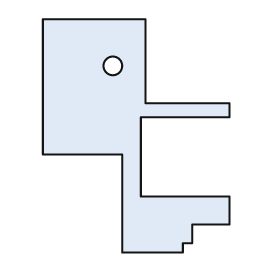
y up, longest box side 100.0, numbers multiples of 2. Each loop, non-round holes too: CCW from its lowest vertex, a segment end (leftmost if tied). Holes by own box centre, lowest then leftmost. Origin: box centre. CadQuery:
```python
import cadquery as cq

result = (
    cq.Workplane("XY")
    .moveTo(-6.0, -50.0)
    .lineTo(20.0, -50.0)
    .lineTo(20.0, -46.0)
    .lineTo(24.0, -46.0)
    .lineTo(24.0, -38.0)
    .lineTo(40.0, -38.0)
    .lineTo(40.0, -26.0)
    .lineTo(2.0, -26.0)
    .lineTo(2.0, 8.0)
    .lineTo(40.0, 8.0)
    .lineTo(40.0, 14.0)
    .lineTo(4.0, 14.0)
    .lineTo(4.0, 50.0)
    .lineTo(-40.0, 50.0)
    .lineTo(-40.0, -8.0)
    .lineTo(-6.0, -8.0)
    .close()
    .moveTo(-10.0, 30.0)
    .circle(4.0)
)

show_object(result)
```